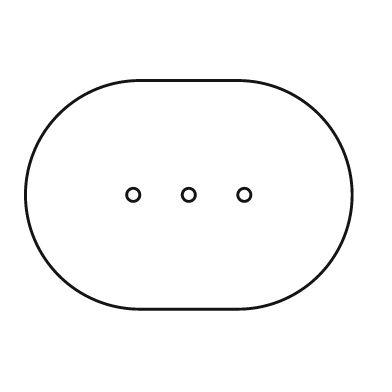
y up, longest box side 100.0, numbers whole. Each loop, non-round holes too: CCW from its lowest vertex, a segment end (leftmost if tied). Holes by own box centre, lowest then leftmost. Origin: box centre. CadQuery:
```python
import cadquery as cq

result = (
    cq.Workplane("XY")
    .moveTo(-15.0, -35.0)
    .lineTo(15.0, -35.0)
    .threePointArc((50.0, 0.0), (15.0, 35.0))
    .lineTo(-15.0, 35.0)
    .threePointArc((-50.0, 0.0), (-15.0, -35.0))
    .close()
    .moveTo(-17.0, 0.0)
    .circle(2.0)
    .moveTo(0.0, 0.0)
    .circle(2.0)
    .moveTo(17.0, 0.0)
    .circle(2.0)
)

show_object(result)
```